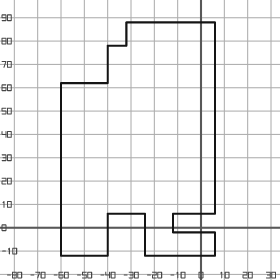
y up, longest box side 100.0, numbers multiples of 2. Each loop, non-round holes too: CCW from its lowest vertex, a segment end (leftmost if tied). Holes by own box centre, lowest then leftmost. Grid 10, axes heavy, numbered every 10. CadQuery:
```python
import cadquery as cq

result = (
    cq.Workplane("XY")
    .moveTo(-60.0, -12.0)
    .lineTo(-40.0, -12.0)
    .lineTo(-40.0, 6.0)
    .lineTo(-24.0, 6.0)
    .lineTo(-24.0, -12.0)
    .lineTo(6.0, -12.0)
    .lineTo(6.0, -2.0)
    .lineTo(-12.0, -2.0)
    .lineTo(-12.0, 6.0)
    .lineTo(6.0, 6.0)
    .lineTo(6.0, 88.0)
    .lineTo(-32.0, 88.0)
    .lineTo(-32.0, 78.0)
    .lineTo(-40.0, 78.0)
    .lineTo(-40.0, 62.0)
    .lineTo(-60.0, 62.0)
    .close()
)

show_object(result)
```